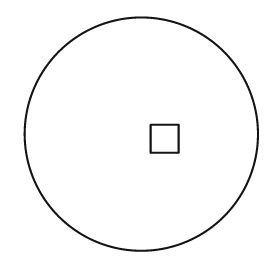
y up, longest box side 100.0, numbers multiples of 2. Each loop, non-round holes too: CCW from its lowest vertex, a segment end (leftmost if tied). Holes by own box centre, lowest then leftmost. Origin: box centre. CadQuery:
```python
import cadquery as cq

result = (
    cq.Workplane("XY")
    .moveTo(0.0, 0.0)
    .circle(50.0)
    .moveTo(4.0, -8.0)
    .lineTo(16.0, -8.0)
    .lineTo(16.0, 4.0)
    .lineTo(4.0, 4.0)
    .close()
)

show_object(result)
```